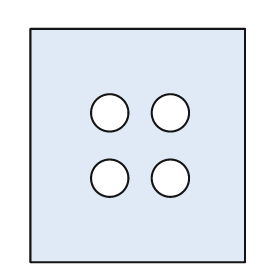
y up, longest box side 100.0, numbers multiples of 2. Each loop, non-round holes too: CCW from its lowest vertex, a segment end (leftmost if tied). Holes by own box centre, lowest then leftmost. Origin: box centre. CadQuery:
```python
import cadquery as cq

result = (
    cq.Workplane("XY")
    .moveTo(-46.0, -50.0)
    .lineTo(46.0, -50.0)
    .lineTo(46.0, 50.0)
    .lineTo(-46.0, 50.0)
    .close()
    .moveTo(-12.0, -14.0)
    .circle(8.0)
    .moveTo(14.0, -14.0)
    .circle(8.0)
    .moveTo(-12.0, 14.0)
    .circle(8.0)
    .moveTo(14.0, 14.0)
    .circle(8.0)
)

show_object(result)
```